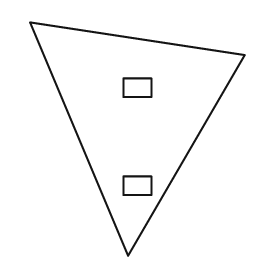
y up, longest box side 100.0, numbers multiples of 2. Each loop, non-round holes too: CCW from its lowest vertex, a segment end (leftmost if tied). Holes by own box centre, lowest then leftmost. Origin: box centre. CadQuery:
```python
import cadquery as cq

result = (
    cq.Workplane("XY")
    .moveTo(-4.0, -50.0)
    .lineTo(46.0, 36.0)
    .lineTo(-46.0, 50.0)
    .close()
    .moveTo(-6.0, -24.0)
    .lineTo(6.0, -24.0)
    .lineTo(6.0, -16.0)
    .lineTo(-6.0, -16.0)
    .close()
    .moveTo(-6.0, 18.0)
    .lineTo(6.0, 18.0)
    .lineTo(6.0, 26.0)
    .lineTo(-6.0, 26.0)
    .close()
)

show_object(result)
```